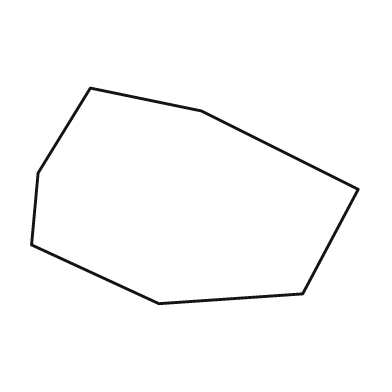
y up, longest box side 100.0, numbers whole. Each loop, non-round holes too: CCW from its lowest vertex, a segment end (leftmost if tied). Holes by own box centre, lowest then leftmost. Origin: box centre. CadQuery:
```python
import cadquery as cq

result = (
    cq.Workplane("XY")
    .moveTo(-11.0, -33.0)
    .lineTo(33.0, -30.0)
    .lineTo(50.0, 2.0)
    .lineTo(2.0, 26.0)
    .lineTo(-32.0, 33.0)
    .lineTo(-48.0, 7.0)
    .lineTo(-50.0, -15.0)
    .close()
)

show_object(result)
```